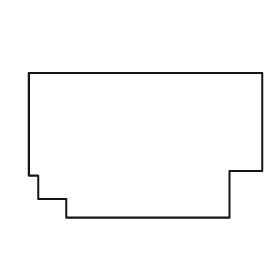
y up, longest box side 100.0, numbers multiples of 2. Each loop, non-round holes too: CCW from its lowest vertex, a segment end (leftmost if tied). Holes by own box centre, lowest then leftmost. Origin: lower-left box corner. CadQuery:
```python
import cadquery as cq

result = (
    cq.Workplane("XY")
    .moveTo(16.0, 0.0)
    .lineTo(86.0, 0.0)
    .lineTo(86.0, 20.0)
    .lineTo(100.0, 20.0)
    .lineTo(100.0, 62.0)
    .lineTo(0.0, 62.0)
    .lineTo(0.0, 18.0)
    .lineTo(4.0, 18.0)
    .lineTo(4.0, 8.0)
    .lineTo(16.0, 8.0)
    .close()
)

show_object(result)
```